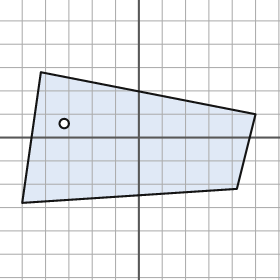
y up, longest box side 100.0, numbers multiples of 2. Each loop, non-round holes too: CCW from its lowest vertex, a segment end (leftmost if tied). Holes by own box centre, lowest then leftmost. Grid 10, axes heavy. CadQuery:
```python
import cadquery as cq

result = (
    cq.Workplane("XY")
    .moveTo(-50.0, -28.0)
    .lineTo(42.0, -22.0)
    .lineTo(50.0, 10.0)
    .lineTo(-42.0, 28.0)
    .close()
    .moveTo(-32.0, 6.0)
    .circle(2.0)
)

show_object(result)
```